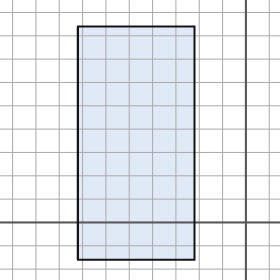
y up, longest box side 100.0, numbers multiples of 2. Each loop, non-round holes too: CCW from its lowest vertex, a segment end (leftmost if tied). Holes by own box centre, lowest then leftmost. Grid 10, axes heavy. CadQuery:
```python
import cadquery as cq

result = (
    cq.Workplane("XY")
    .moveTo(-72.0, -16.0)
    .lineTo(-22.0, -16.0)
    .lineTo(-22.0, 84.0)
    .lineTo(-72.0, 84.0)
    .close()
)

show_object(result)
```